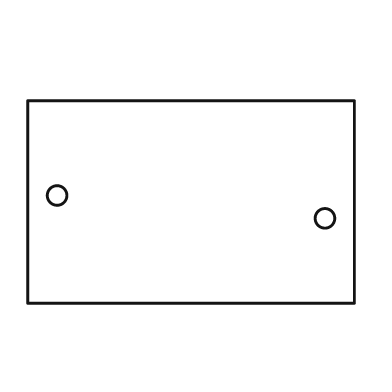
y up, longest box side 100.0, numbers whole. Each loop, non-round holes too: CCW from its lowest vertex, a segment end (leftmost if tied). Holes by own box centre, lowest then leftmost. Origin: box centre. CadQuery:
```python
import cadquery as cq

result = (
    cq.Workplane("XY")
    .moveTo(-50.0, -31.0)
    .lineTo(50.0, -31.0)
    .lineTo(50.0, 31.0)
    .lineTo(-50.0, 31.0)
    .close()
    .moveTo(41.0, -5.0)
    .circle(3.0)
    .moveTo(-41.0, 2.0)
    .circle(3.0)
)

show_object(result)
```